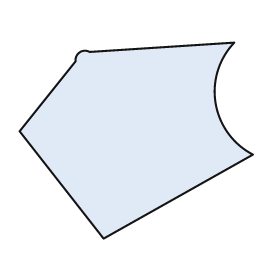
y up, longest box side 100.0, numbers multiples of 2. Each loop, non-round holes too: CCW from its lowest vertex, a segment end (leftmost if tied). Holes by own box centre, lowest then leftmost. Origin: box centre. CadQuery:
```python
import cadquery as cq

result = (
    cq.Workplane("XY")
    .moveTo(-14.0, -42.0)
    .lineTo(50.0, -6.0)
    .threePointArc((34.0, 16.0), (42.0, 42.0))
    .lineTo(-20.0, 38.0)
    .threePointArc((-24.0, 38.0), (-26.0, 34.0))
    .lineTo(-50.0, 4.0)
    .close()
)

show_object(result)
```